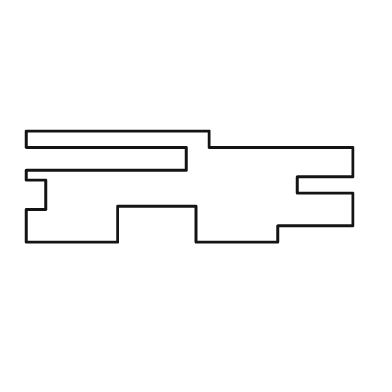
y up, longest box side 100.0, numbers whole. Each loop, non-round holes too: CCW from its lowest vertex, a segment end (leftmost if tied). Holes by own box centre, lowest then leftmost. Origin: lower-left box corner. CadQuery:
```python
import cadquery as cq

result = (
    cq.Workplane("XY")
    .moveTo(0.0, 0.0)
    .lineTo(28.0, 0.0)
    .lineTo(28.0, 11.0)
    .lineTo(52.0, 11.0)
    .lineTo(52.0, 0.0)
    .lineTo(77.0, 0.0)
    .lineTo(77.0, 5.0)
    .lineTo(100.0, 5.0)
    .lineTo(100.0, 15.0)
    .lineTo(83.0, 15.0)
    .lineTo(83.0, 20.0)
    .lineTo(100.0, 20.0)
    .lineTo(100.0, 29.0)
    .lineTo(56.0, 29.0)
    .lineTo(56.0, 34.0)
    .lineTo(0.0, 34.0)
    .lineTo(0.0, 29.0)
    .lineTo(49.0, 29.0)
    .lineTo(49.0, 22.0)
    .lineTo(0.0, 22.0)
    .lineTo(0.0, 19.0)
    .lineTo(6.0, 19.0)
    .lineTo(6.0, 10.0)
    .lineTo(0.0, 10.0)
    .close()
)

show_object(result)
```